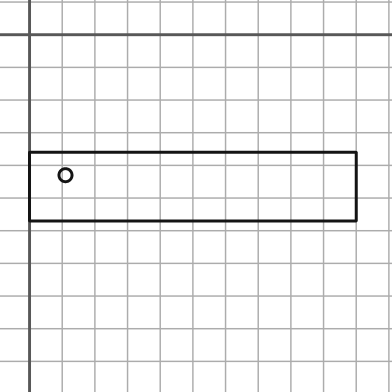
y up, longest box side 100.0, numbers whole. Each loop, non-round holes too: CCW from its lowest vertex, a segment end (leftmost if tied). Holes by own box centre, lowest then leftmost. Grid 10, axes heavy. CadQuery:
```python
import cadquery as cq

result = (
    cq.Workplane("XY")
    .moveTo(0.0, -57.0)
    .lineTo(100.0, -57.0)
    .lineTo(100.0, -36.0)
    .lineTo(0.0, -36.0)
    .close()
    .moveTo(11.0, -43.0)
    .circle(2.0)
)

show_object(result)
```